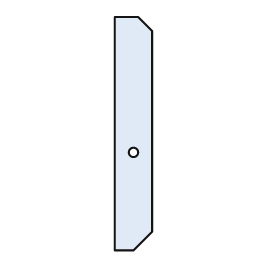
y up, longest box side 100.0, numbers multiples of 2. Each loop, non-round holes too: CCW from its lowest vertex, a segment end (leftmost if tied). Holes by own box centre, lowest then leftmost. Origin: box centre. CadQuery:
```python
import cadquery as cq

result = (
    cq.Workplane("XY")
    .moveTo(-8.0, -50.0)
    .lineTo(0.0, -50.0)
    .lineTo(8.0, -42.0)
    .lineTo(8.0, 44.0)
    .lineTo(2.0, 50.0)
    .lineTo(-8.0, 50.0)
    .close()
    .moveTo(0.0, -8.0)
    .circle(2.0)
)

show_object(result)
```